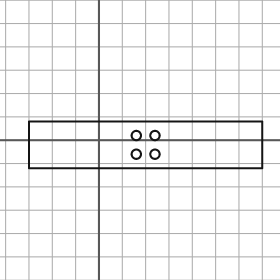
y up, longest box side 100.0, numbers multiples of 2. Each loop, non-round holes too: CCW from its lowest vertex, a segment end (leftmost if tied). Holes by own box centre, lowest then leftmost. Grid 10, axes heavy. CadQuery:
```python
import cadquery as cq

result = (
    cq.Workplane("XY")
    .moveTo(-30.0, -12.0)
    .lineTo(70.0, -12.0)
    .lineTo(70.0, 8.0)
    .lineTo(-30.0, 8.0)
    .close()
    .moveTo(16.0, -6.0)
    .circle(2.0)
    .moveTo(24.0, -6.0)
    .circle(2.0)
    .moveTo(16.0, 2.0)
    .circle(2.0)
    .moveTo(24.0, 2.0)
    .circle(2.0)
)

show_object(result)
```